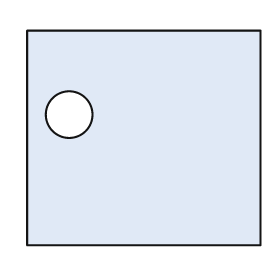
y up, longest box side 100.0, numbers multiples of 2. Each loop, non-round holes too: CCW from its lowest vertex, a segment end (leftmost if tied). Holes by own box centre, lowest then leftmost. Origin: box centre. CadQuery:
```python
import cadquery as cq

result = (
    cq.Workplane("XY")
    .moveTo(-50.0, -46.0)
    .lineTo(50.0, -46.0)
    .lineTo(50.0, 46.0)
    .lineTo(-50.0, 46.0)
    .close()
    .moveTo(-32.0, 10.0)
    .circle(10.0)
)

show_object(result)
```